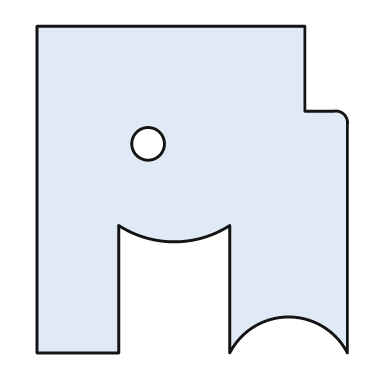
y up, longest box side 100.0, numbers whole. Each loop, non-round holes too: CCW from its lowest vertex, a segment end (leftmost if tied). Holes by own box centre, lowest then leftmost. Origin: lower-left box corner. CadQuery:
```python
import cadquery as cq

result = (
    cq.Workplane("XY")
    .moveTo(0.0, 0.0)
    .lineTo(25.0, 0.0)
    .lineTo(25.0, 39.0)
    .threePointArc((42.0, 34.0), (59.0, 39.0))
    .lineTo(59.0, 0.0)
    .threePointArc((77.0, 11.0), (95.0, 0.0))
    .lineTo(95.0, 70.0)
    .threePointArc((94.0, 73.0), (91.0, 74.0))
    .lineTo(82.0, 74.0)
    .lineTo(82.0, 100.0)
    .lineTo(0.0, 100.0)
    .close()
    .moveTo(34.0, 64.0)
    .circle(5.0)
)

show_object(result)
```